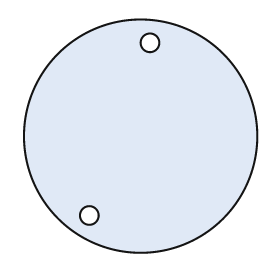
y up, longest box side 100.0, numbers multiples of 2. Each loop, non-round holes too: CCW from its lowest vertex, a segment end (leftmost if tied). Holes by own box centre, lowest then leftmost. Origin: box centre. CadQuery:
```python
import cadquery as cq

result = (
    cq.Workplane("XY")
    .moveTo(0.0, 0.0)
    .circle(50.0)
    .moveTo(-22.0, -34.0)
    .circle(4.0)
    .moveTo(4.0, 40.0)
    .circle(4.0)
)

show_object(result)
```